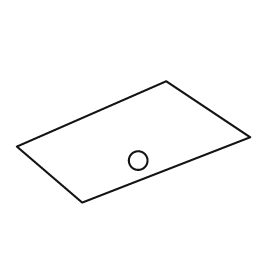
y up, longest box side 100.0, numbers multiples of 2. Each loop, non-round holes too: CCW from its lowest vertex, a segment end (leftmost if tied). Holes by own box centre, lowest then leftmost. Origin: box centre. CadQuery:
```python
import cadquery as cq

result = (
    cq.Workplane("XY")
    .moveTo(-22.0, -26.0)
    .lineTo(50.0, 2.0)
    .lineTo(14.0, 26.0)
    .lineTo(-50.0, -2.0)
    .close()
    .moveTo(2.0, -8.0)
    .circle(4.0)
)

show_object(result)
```